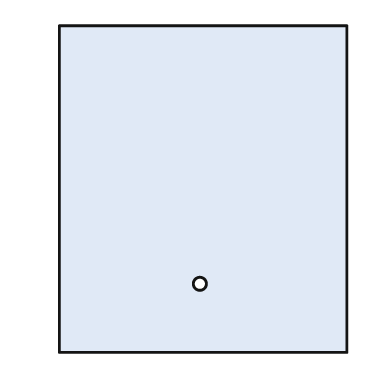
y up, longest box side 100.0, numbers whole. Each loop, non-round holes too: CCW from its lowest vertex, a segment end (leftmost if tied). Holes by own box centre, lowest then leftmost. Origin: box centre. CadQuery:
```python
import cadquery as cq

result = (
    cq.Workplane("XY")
    .moveTo(-44.0, -50.0)
    .lineTo(44.0, -50.0)
    .lineTo(44.0, 50.0)
    .lineTo(-44.0, 50.0)
    .close()
    .moveTo(-1.0, -29.0)
    .circle(2.0)
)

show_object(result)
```